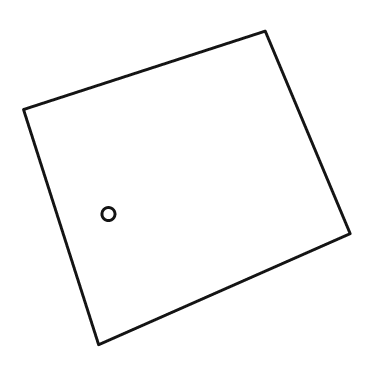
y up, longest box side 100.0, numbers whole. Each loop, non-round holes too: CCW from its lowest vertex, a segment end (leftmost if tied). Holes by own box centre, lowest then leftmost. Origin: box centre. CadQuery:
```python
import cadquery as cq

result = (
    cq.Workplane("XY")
    .moveTo(-27.0, -48.0)
    .lineTo(50.0, -14.0)
    .lineTo(24.0, 48.0)
    .lineTo(-50.0, 24.0)
    .close()
    .moveTo(-24.0, -8.0)
    .circle(2.0)
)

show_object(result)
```